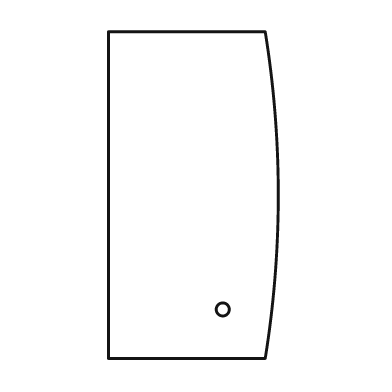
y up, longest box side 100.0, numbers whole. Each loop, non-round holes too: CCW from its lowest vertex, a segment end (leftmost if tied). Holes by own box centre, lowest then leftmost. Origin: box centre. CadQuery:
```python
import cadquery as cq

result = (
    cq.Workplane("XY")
    .moveTo(-26.0, -50.0)
    .lineTo(22.0, -50.0)
    .threePointArc((26.0, 0.0), (22.0, 50.0))
    .lineTo(-26.0, 50.0)
    .close()
    .moveTo(9.0, -35.0)
    .circle(2.0)
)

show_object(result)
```